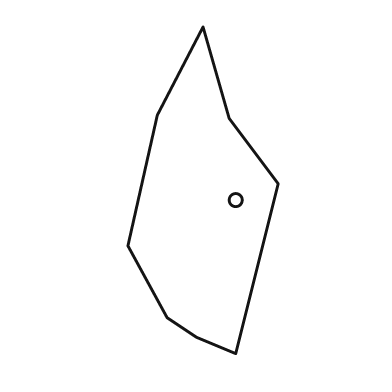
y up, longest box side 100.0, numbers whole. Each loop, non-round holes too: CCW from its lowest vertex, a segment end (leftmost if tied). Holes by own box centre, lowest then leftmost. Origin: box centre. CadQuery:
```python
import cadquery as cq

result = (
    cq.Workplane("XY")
    .moveTo(10.0, -50.0)
    .lineTo(23.0, 2.0)
    .lineTo(8.0, 22.0)
    .lineTo(0.0, 50.0)
    .lineTo(-14.0, 23.0)
    .lineTo(-23.0, -17.0)
    .lineTo(-11.0, -39.0)
    .lineTo(-2.0, -45.0)
    .close()
    .moveTo(10.0, -3.0)
    .circle(2.0)
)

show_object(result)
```